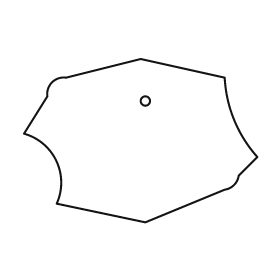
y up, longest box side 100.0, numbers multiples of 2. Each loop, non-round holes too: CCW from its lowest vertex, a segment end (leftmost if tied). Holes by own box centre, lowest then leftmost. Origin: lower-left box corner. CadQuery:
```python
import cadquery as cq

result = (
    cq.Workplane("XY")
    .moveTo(52.0, 0.0)
    .lineTo(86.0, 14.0)
    .threePointArc((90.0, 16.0), (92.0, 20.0))
    .lineTo(100.0, 28.0)
    .threePointArc((90.0, 44.0), (86.0, 62.0))
    .lineTo(50.0, 70.0)
    .lineTo(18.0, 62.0)
    .threePointArc((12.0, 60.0), (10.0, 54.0))
    .lineTo(0.0, 38.0)
    .threePointArc((14.0, 26.0), (14.0, 8.0))
    .close()
    .moveTo(52.0, 52.0)
    .circle(2.0)
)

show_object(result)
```